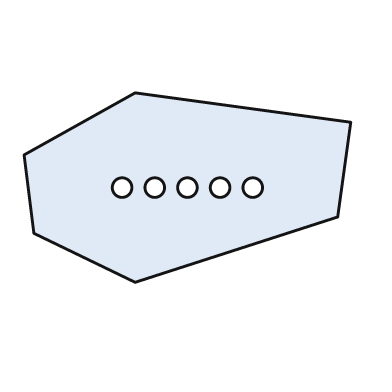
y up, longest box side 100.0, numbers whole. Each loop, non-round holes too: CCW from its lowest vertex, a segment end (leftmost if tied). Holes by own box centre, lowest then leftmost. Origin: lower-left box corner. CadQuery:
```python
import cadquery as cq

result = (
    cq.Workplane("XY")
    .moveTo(34.0, 0.0)
    .lineTo(96.0, 20.0)
    .lineTo(100.0, 49.0)
    .lineTo(34.0, 58.0)
    .lineTo(0.0, 39.0)
    .lineTo(3.0, 15.0)
    .close()
    .moveTo(30.0, 29.0)
    .circle(3.0)
    .moveTo(40.0, 29.0)
    .circle(3.0)
    .moveTo(50.0, 29.0)
    .circle(3.0)
    .moveTo(60.0, 29.0)
    .circle(3.0)
    .moveTo(70.0, 29.0)
    .circle(3.0)
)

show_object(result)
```